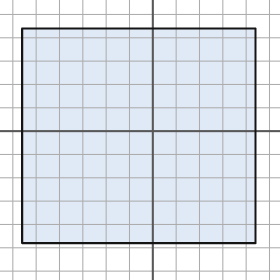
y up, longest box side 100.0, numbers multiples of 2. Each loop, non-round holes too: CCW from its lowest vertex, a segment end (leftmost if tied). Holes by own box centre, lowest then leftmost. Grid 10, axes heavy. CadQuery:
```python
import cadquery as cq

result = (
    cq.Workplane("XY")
    .moveTo(-56.0, -48.0)
    .lineTo(44.0, -48.0)
    .lineTo(44.0, 44.0)
    .lineTo(-56.0, 44.0)
    .close()
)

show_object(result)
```